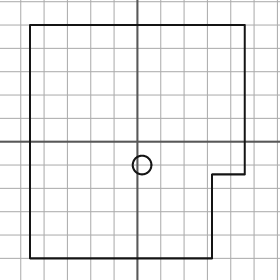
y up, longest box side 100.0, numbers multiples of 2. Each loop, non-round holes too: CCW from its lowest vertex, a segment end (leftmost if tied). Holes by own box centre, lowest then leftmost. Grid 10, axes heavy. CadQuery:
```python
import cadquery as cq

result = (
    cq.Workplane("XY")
    .moveTo(-46.0, -50.0)
    .lineTo(32.0, -50.0)
    .lineTo(32.0, -14.0)
    .lineTo(46.0, -14.0)
    .lineTo(46.0, 50.0)
    .lineTo(-46.0, 50.0)
    .close()
    .moveTo(2.0, -10.0)
    .circle(4.0)
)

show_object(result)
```